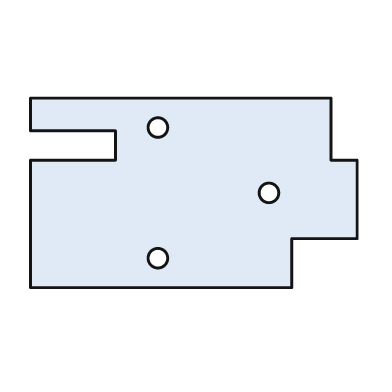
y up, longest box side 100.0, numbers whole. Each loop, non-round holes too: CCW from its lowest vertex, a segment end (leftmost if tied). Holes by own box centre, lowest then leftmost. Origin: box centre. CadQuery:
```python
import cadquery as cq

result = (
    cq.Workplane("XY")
    .moveTo(-50.0, -29.0)
    .lineTo(30.0, -29.0)
    .lineTo(30.0, -14.0)
    .lineTo(50.0, -14.0)
    .lineTo(50.0, 10.0)
    .lineTo(42.0, 10.0)
    .lineTo(42.0, 29.0)
    .lineTo(-50.0, 29.0)
    .lineTo(-50.0, 19.0)
    .lineTo(-24.0, 19.0)
    .lineTo(-24.0, 10.0)
    .lineTo(-50.0, 10.0)
    .close()
    .moveTo(-11.0, -20.0)
    .circle(3.0)
    .moveTo(23.0, 0.0)
    .circle(3.0)
    .moveTo(-11.0, 20.0)
    .circle(3.0)
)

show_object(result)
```